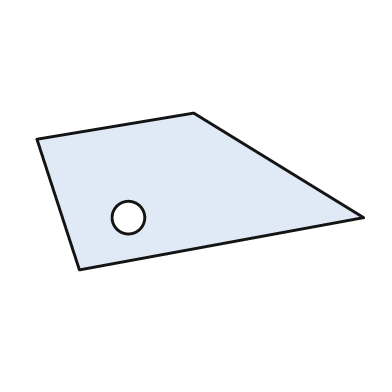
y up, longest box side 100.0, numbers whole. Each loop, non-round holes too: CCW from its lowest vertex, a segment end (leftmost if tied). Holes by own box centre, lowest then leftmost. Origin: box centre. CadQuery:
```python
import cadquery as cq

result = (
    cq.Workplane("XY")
    .moveTo(-37.0, -24.0)
    .lineTo(50.0, -8.0)
    .lineTo(-2.0, 24.0)
    .lineTo(-50.0, 16.0)
    .close()
    .moveTo(-22.0, -8.0)
    .circle(5.0)
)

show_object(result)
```